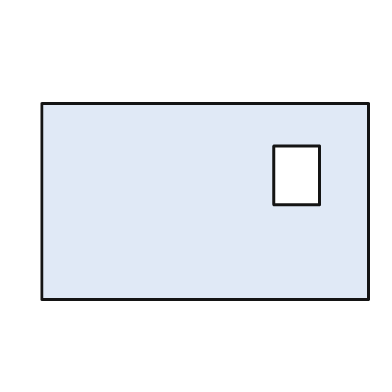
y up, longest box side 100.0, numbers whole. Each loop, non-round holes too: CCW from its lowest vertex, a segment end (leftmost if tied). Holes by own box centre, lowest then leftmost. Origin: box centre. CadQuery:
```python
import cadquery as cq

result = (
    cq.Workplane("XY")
    .moveTo(-50.0, -30.0)
    .lineTo(50.0, -30.0)
    .lineTo(50.0, 30.0)
    .lineTo(-50.0, 30.0)
    .close()
    .moveTo(21.0, -1.0)
    .lineTo(35.0, -1.0)
    .lineTo(35.0, 17.0)
    .lineTo(21.0, 17.0)
    .close()
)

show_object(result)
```